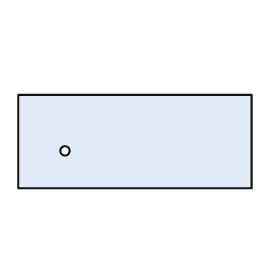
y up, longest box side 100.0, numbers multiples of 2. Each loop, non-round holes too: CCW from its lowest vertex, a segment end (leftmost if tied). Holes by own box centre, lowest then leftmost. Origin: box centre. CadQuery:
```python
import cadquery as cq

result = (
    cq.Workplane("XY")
    .moveTo(-50.0, -20.0)
    .lineTo(50.0, -20.0)
    .lineTo(50.0, 20.0)
    .lineTo(-50.0, 20.0)
    .close()
    .moveTo(-30.0, -4.0)
    .circle(2.0)
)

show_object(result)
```